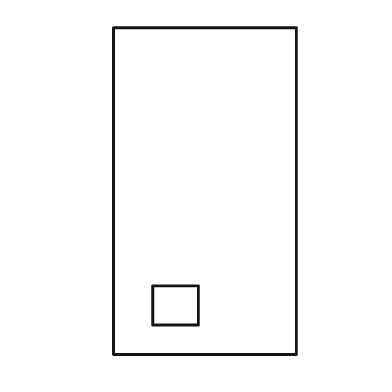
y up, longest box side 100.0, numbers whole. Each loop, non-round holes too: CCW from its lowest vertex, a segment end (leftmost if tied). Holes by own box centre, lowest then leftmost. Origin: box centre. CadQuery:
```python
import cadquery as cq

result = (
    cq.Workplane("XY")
    .moveTo(-28.0, -50.0)
    .lineTo(28.0, -50.0)
    .lineTo(28.0, 50.0)
    .lineTo(-28.0, 50.0)
    .close()
    .moveTo(-16.0, -41.0)
    .lineTo(-2.0, -41.0)
    .lineTo(-2.0, -29.0)
    .lineTo(-16.0, -29.0)
    .close()
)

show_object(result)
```